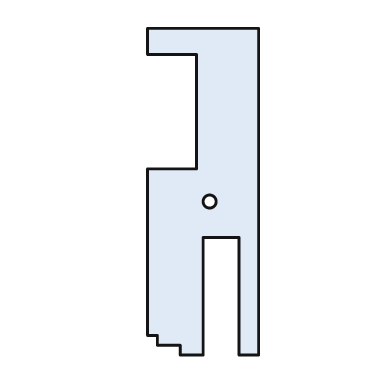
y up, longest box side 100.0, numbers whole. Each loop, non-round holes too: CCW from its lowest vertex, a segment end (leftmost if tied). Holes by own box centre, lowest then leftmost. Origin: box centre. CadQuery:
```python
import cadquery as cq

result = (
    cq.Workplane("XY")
    .moveTo(-7.0, -50.0)
    .lineTo(0.0, -50.0)
    .lineTo(0.0, -14.0)
    .lineTo(11.0, -14.0)
    .lineTo(11.0, -50.0)
    .lineTo(17.0, -50.0)
    .lineTo(17.0, 50.0)
    .lineTo(-17.0, 50.0)
    .lineTo(-17.0, 42.0)
    .lineTo(-2.0, 42.0)
    .lineTo(-2.0, 7.0)
    .lineTo(-17.0, 7.0)
    .lineTo(-17.0, -44.0)
    .lineTo(-14.0, -44.0)
    .lineTo(-14.0, -47.0)
    .lineTo(-7.0, -47.0)
    .close()
    .moveTo(2.0, -3.0)
    .circle(2.0)
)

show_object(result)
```